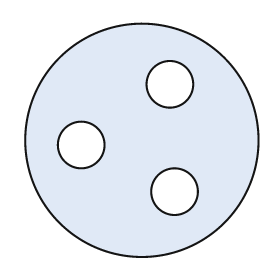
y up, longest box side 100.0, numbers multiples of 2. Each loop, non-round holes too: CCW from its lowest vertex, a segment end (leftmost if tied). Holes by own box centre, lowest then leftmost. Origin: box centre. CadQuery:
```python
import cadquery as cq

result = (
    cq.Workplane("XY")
    .moveTo(0.0, 0.0)
    .circle(50.0)
    .moveTo(14.0, -22.0)
    .circle(10.0)
    .moveTo(-26.0, -2.0)
    .circle(10.0)
    .moveTo(12.0, 24.0)
    .circle(10.0)
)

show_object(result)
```